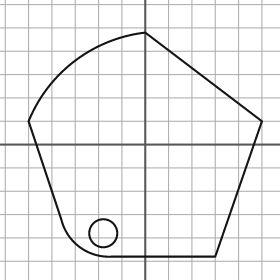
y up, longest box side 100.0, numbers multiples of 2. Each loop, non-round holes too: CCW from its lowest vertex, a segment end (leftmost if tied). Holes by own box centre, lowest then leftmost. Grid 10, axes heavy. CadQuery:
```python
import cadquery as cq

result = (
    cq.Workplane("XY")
    .moveTo(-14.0, -48.0)
    .lineTo(30.0, -48.0)
    .lineTo(50.0, 10.0)
    .lineTo(0.0, 48.0)
    .threePointArc((-30.0, 36.0), (-50.0, 10.0))
    .lineTo(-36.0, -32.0)
    .threePointArc((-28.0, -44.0), (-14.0, -48.0))
    .close()
    .moveTo(-18.0, -38.0)
    .circle(6.0)
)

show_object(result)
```